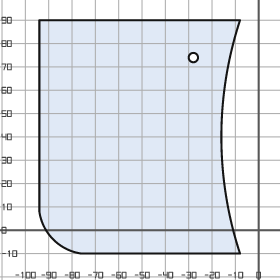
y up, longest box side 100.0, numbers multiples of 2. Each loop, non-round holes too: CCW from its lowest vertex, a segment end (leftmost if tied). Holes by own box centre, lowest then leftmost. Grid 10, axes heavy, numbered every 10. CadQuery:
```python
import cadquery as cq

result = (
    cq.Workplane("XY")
    .moveTo(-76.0, -10.0)
    .lineTo(-8.0, -10.0)
    .threePointArc((-16.0, 40.0), (-8.0, 90.0))
    .lineTo(-94.0, 90.0)
    .lineTo(-94.0, 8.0)
    .threePointArc((-88.0, -4.0), (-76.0, -10.0))
    .close()
    .moveTo(-28.0, 74.0)
    .circle(2.0)
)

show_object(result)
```